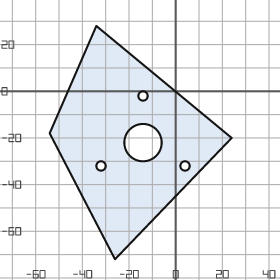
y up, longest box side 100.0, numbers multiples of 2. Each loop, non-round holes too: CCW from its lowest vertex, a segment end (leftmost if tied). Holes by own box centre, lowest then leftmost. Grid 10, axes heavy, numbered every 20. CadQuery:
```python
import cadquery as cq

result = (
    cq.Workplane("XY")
    .moveTo(-26.0, -72.0)
    .lineTo(24.0, -20.0)
    .lineTo(-34.0, 28.0)
    .lineTo(-54.0, -18.0)
    .close()
    .moveTo(-32.0, -32.0)
    .circle(2.0)
    .moveTo(4.0, -32.0)
    .circle(2.0)
    .moveTo(-14.0, -22.0)
    .circle(8.0)
    .moveTo(-14.0, -2.0)
    .circle(2.0)
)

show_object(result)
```